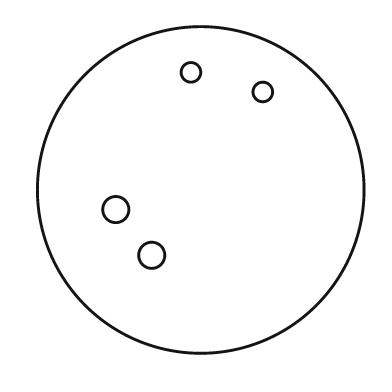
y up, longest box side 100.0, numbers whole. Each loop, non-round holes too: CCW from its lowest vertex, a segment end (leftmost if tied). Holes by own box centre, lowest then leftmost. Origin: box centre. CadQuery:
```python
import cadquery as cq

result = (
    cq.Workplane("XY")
    .moveTo(0.0, 0.0)
    .circle(50.0)
    .moveTo(-15.0, -20.0)
    .circle(4.0)
    .moveTo(-26.0, -6.0)
    .circle(4.0)
    .moveTo(19.0, 30.0)
    .circle(3.0)
    .moveTo(-3.0, 36.0)
    .circle(3.0)
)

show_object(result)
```